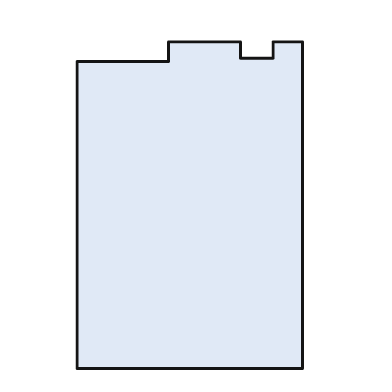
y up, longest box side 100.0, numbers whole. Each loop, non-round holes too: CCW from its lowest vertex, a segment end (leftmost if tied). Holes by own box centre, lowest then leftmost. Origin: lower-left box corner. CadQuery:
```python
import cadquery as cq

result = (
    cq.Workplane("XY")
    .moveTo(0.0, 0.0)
    .lineTo(69.0, 0.0)
    .lineTo(69.0, 100.0)
    .lineTo(60.0, 100.0)
    .lineTo(60.0, 95.0)
    .lineTo(50.0, 95.0)
    .lineTo(50.0, 100.0)
    .lineTo(28.0, 100.0)
    .lineTo(28.0, 94.0)
    .lineTo(0.0, 94.0)
    .close()
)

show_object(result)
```